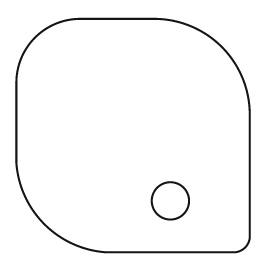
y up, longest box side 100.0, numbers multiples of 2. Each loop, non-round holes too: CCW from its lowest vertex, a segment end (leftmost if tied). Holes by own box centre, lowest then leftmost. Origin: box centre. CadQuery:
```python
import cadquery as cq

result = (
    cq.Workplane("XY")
    .moveTo(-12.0, -50.0)
    .lineTo(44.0, -50.0)
    .threePointArc((48.0, -48.0), (50.0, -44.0))
    .lineTo(50.0, 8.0)
    .threePointArc((38.0, 38.0), (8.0, 50.0))
    .lineTo(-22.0, 50.0)
    .threePointArc((-42.0, 42.0), (-50.0, 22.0))
    .lineTo(-50.0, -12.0)
    .threePointArc((-38.0, -38.0), (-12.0, -50.0))
    .close()
    .moveTo(16.0, -28.0)
    .circle(8.0)
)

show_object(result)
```